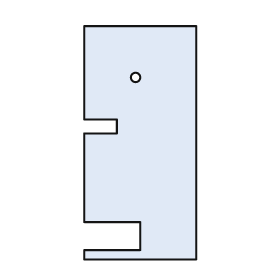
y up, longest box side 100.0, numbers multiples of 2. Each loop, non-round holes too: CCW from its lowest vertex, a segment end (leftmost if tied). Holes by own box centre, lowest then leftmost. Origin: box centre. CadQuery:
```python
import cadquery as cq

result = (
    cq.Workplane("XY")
    .moveTo(-24.0, -50.0)
    .lineTo(24.0, -50.0)
    .lineTo(24.0, 50.0)
    .lineTo(-24.0, 50.0)
    .lineTo(-24.0, 10.0)
    .lineTo(-10.0, 10.0)
    .lineTo(-10.0, 4.0)
    .lineTo(-24.0, 4.0)
    .lineTo(-24.0, -34.0)
    .lineTo(0.0, -34.0)
    .lineTo(0.0, -46.0)
    .lineTo(-24.0, -46.0)
    .close()
    .moveTo(-2.0, 28.0)
    .circle(2.0)
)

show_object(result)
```